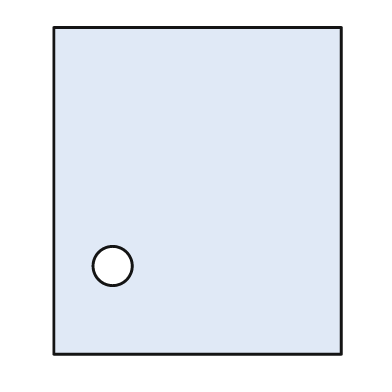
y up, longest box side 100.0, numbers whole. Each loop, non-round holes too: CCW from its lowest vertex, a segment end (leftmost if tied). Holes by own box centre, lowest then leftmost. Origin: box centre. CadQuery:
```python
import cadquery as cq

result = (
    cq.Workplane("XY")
    .moveTo(-44.0, -50.0)
    .lineTo(44.0, -50.0)
    .lineTo(44.0, 50.0)
    .lineTo(-44.0, 50.0)
    .close()
    .moveTo(-26.0, -23.0)
    .circle(6.0)
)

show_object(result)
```